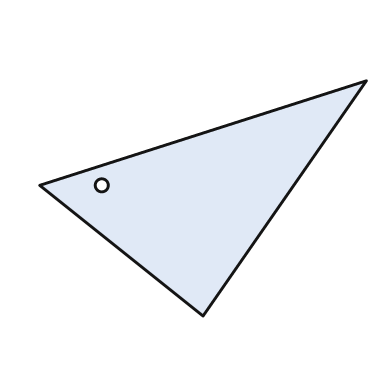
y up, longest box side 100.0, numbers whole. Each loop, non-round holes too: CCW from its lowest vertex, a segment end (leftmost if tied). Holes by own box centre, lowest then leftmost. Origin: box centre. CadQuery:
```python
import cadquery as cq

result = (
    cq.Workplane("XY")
    .moveTo(0.0, -36.0)
    .lineTo(50.0, 36.0)
    .lineTo(-50.0, 4.0)
    .close()
    .moveTo(-31.0, 4.0)
    .circle(2.0)
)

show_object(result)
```